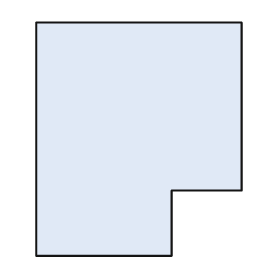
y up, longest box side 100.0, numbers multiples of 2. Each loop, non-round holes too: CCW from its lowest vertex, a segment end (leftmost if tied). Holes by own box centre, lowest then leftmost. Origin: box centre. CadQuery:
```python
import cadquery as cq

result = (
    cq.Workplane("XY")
    .moveTo(-44.0, -50.0)
    .lineTo(14.0, -50.0)
    .lineTo(14.0, -22.0)
    .lineTo(44.0, -22.0)
    .lineTo(44.0, 50.0)
    .lineTo(-44.0, 50.0)
    .close()
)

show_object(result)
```